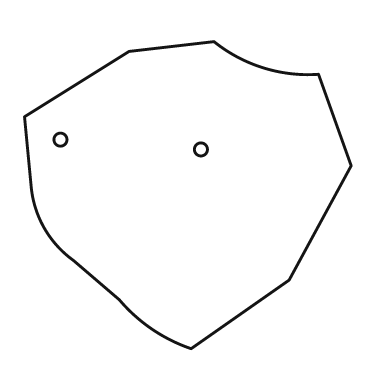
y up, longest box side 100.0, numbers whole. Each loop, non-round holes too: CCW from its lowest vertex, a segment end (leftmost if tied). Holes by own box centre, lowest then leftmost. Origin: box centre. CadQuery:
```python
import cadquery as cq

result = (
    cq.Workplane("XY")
    .moveTo(1.0, -47.0)
    .lineTo(31.0, -26.0)
    .lineTo(50.0, 9.0)
    .lineTo(40.0, 37.0)
    .threePointArc((23.0, 39.0), (8.0, 47.0))
    .lineTo(-18.0, 44.0)
    .lineTo(-50.0, 24.0)
    .lineTo(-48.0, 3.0)
    .threePointArc((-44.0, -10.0), (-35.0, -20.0))
    .lineTo(-21.0, -32.0)
    .threePointArc((-11.0, -41.0), (1.0, -47.0))
    .close()
    .moveTo(4.0, 14.0)
    .circle(2.0)
    .moveTo(-39.0, 17.0)
    .circle(2.0)
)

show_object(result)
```